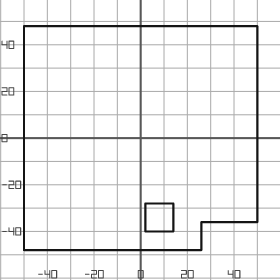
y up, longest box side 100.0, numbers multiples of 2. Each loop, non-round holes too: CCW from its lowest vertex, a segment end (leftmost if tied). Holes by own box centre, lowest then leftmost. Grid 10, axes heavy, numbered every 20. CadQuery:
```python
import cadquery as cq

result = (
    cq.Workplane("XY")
    .moveTo(-50.0, -48.0)
    .lineTo(26.0, -48.0)
    .lineTo(26.0, -36.0)
    .lineTo(50.0, -36.0)
    .lineTo(50.0, 48.0)
    .lineTo(-50.0, 48.0)
    .close()
    .moveTo(2.0, -40.0)
    .lineTo(14.0, -40.0)
    .lineTo(14.0, -28.0)
    .lineTo(2.0, -28.0)
    .close()
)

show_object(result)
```